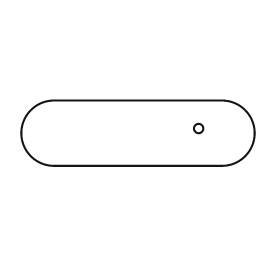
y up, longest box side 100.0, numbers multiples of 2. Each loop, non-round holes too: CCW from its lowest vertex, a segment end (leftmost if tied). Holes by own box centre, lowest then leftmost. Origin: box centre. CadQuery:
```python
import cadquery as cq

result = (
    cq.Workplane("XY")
    .moveTo(-36.0, -14.0)
    .lineTo(36.0, -14.0)
    .threePointArc((50.0, 0.0), (36.0, 14.0))
    .lineTo(-36.0, 14.0)
    .threePointArc((-50.0, 0.0), (-36.0, -14.0))
    .close()
    .moveTo(26.0, 2.0)
    .circle(2.0)
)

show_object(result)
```